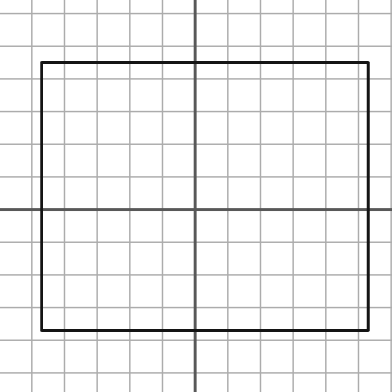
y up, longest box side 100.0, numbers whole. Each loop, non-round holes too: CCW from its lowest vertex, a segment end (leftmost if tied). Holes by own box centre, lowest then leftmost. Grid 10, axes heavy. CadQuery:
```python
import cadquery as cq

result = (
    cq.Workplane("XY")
    .moveTo(-47.0, -37.0)
    .lineTo(53.0, -37.0)
    .lineTo(53.0, 45.0)
    .lineTo(-47.0, 45.0)
    .close()
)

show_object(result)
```